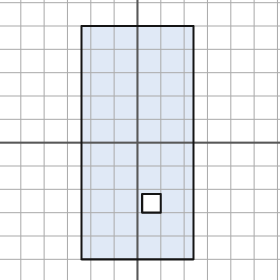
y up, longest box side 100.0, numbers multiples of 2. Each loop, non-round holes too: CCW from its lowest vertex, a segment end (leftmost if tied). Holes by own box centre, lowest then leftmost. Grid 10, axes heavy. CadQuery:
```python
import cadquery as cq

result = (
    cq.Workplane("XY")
    .moveTo(-24.0, -50.0)
    .lineTo(24.0, -50.0)
    .lineTo(24.0, 50.0)
    .lineTo(-24.0, 50.0)
    .close()
    .moveTo(2.0, -30.0)
    .lineTo(10.0, -30.0)
    .lineTo(10.0, -22.0)
    .lineTo(2.0, -22.0)
    .close()
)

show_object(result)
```